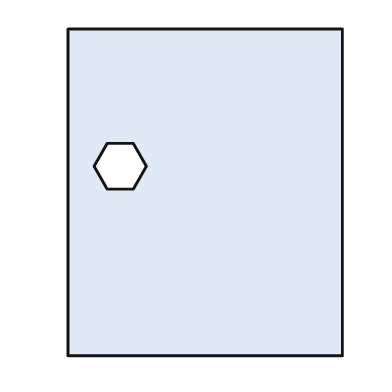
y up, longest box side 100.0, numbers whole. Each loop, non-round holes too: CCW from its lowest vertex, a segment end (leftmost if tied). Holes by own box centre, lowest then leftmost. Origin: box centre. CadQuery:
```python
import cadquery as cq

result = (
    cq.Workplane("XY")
    .moveTo(-42.0, -50.0)
    .lineTo(42.0, -50.0)
    .lineTo(42.0, 50.0)
    .lineTo(-42.0, 50.0)
    .close()
    .moveTo(-30.0, 1.0)
    .lineTo(-22.0, 1.0)
    .lineTo(-18.0, 8.0)
    .lineTo(-22.0, 15.0)
    .lineTo(-30.0, 15.0)
    .lineTo(-34.0, 8.0)
    .close()
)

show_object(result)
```